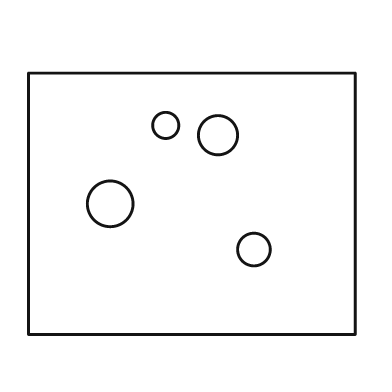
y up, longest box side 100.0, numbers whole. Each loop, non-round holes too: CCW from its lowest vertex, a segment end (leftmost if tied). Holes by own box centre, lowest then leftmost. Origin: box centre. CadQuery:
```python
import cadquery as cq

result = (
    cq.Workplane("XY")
    .moveTo(-50.0, -40.0)
    .lineTo(50.0, -40.0)
    .lineTo(50.0, 40.0)
    .lineTo(-50.0, 40.0)
    .close()
    .moveTo(19.0, -14.0)
    .circle(5.0)
    .moveTo(-25.0, 0.0)
    .circle(7.0)
    .moveTo(8.0, 21.0)
    .circle(6.0)
    .moveTo(-8.0, 24.0)
    .circle(4.0)
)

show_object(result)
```